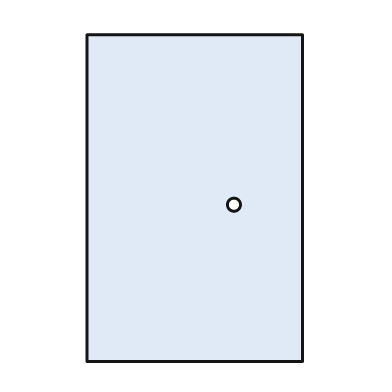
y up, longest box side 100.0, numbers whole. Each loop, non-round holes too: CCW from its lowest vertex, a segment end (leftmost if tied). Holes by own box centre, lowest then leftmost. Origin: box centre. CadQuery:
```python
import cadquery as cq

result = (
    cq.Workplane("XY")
    .moveTo(-33.0, -50.0)
    .lineTo(33.0, -50.0)
    .lineTo(33.0, 50.0)
    .lineTo(-33.0, 50.0)
    .close()
    .moveTo(12.0, -2.0)
    .circle(2.0)
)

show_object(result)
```